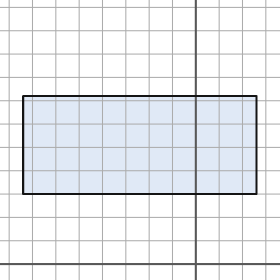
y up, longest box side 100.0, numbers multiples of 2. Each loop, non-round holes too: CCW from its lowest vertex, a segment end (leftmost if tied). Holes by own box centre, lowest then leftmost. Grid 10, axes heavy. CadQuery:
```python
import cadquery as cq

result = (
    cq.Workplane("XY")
    .moveTo(-74.0, 30.0)
    .lineTo(26.0, 30.0)
    .lineTo(26.0, 72.0)
    .lineTo(-74.0, 72.0)
    .close()
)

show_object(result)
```